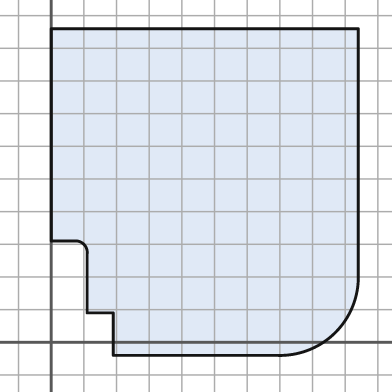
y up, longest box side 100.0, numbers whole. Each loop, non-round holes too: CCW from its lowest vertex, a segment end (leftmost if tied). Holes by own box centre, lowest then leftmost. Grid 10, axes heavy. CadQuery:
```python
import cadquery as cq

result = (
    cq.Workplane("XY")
    .moveTo(19.0, -4.0)
    .lineTo(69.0, -4.0)
    .threePointArc((87.0, 3.0), (94.0, 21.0))
    .lineTo(94.0, 96.0)
    .lineTo(0.0, 96.0)
    .lineTo(0.0, 31.0)
    .lineTo(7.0, 31.0)
    .threePointArc((10.0, 30.0), (11.0, 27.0))
    .lineTo(11.0, 9.0)
    .lineTo(19.0, 9.0)
    .close()
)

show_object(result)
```